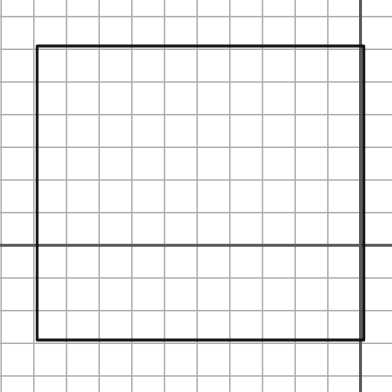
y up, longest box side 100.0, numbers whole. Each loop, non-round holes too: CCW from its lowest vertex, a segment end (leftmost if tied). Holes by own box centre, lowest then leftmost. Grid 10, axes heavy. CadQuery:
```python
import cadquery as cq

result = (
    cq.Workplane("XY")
    .moveTo(-99.0, -29.0)
    .lineTo(1.0, -29.0)
    .lineTo(1.0, 61.0)
    .lineTo(-99.0, 61.0)
    .close()
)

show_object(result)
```